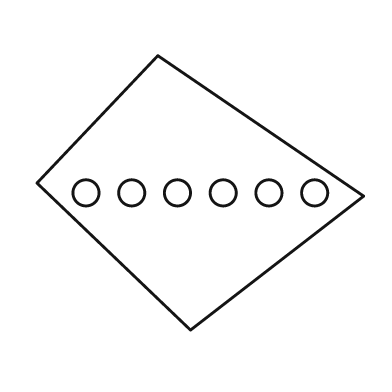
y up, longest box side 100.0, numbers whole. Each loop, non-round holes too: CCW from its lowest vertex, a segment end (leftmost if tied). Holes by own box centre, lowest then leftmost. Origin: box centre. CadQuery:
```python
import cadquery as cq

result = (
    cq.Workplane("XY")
    .moveTo(-3.0, -42.0)
    .lineTo(50.0, -1.0)
    .lineTo(-13.0, 42.0)
    .lineTo(-50.0, 3.0)
    .close()
    .moveTo(-35.0, 0.0)
    .circle(4.0)
    .moveTo(-21.0, 0.0)
    .circle(4.0)
    .moveTo(-7.0, 0.0)
    .circle(4.0)
    .moveTo(7.0, 0.0)
    .circle(4.0)
    .moveTo(21.0, 0.0)
    .circle(4.0)
    .moveTo(35.0, 0.0)
    .circle(4.0)
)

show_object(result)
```